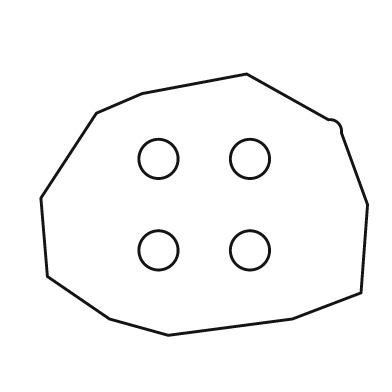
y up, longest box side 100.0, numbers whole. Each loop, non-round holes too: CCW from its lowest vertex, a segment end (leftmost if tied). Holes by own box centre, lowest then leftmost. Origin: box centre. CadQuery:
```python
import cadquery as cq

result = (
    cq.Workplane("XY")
    .moveTo(-11.0, -40.0)
    .lineTo(27.0, -35.0)
    .lineTo(48.0, -27.0)
    .lineTo(50.0, 0.0)
    .lineTo(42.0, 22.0)
    .threePointArc((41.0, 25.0), (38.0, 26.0))
    .lineTo(13.0, 40.0)
    .lineTo(-19.0, 34.0)
    .lineTo(-33.0, 28.0)
    .lineTo(-50.0, 2.0)
    .lineTo(-48.0, -22.0)
    .lineTo(-29.0, -35.0)
    .close()
    .moveTo(-14.0, -14.0)
    .circle(6.0)
    .moveTo(14.0, -14.0)
    .circle(6.0)
    .moveTo(-14.0, 14.0)
    .circle(6.0)
    .moveTo(14.0, 14.0)
    .circle(6.0)
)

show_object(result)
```